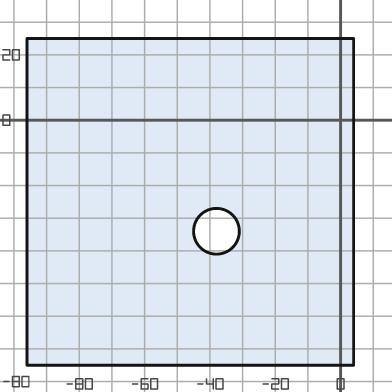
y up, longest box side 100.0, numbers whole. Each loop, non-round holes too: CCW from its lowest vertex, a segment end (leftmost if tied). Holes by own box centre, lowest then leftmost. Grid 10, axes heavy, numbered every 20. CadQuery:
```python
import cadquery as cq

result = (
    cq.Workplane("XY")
    .moveTo(-96.0, -75.0)
    .lineTo(4.0, -75.0)
    .lineTo(4.0, 25.0)
    .lineTo(-96.0, 25.0)
    .close()
    .moveTo(-38.0, -34.0)
    .circle(7.0)
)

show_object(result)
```